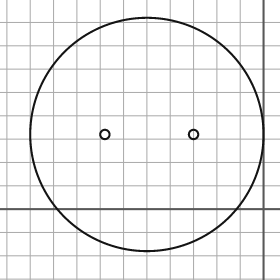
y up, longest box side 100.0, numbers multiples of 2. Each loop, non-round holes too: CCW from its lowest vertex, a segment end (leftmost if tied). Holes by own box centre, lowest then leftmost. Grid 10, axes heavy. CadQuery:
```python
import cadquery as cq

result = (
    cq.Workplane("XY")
    .moveTo(-50.0, 32.0)
    .circle(50.0)
    .moveTo(-68.0, 32.0)
    .circle(2.0)
    .moveTo(-30.0, 32.0)
    .circle(2.0)
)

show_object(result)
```